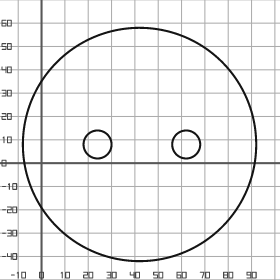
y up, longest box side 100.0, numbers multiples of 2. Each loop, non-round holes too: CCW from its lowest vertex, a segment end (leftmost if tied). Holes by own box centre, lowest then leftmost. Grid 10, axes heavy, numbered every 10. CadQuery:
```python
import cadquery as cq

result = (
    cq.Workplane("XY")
    .moveTo(42.0, 8.0)
    .circle(50.0)
    .moveTo(24.0, 8.0)
    .circle(6.0)
    .moveTo(62.0, 8.0)
    .circle(6.0)
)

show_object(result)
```